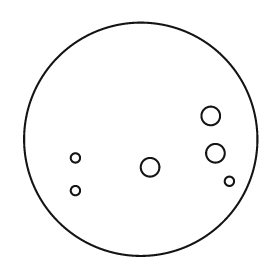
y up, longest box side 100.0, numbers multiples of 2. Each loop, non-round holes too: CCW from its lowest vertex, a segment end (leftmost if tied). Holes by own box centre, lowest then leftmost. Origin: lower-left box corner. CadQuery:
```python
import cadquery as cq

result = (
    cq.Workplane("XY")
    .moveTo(50.0, 50.0)
    .circle(50.0)
    .moveTo(22.0, 28.0)
    .circle(2.0)
    .moveTo(88.0, 32.0)
    .circle(2.0)
    .moveTo(54.0, 38.0)
    .circle(4.0)
    .moveTo(22.0, 42.0)
    .circle(2.0)
    .moveTo(82.0, 44.0)
    .circle(4.0)
    .moveTo(80.0, 60.0)
    .circle(4.0)
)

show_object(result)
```